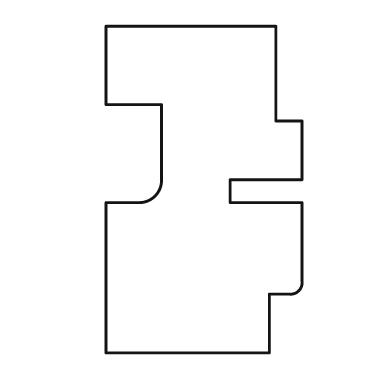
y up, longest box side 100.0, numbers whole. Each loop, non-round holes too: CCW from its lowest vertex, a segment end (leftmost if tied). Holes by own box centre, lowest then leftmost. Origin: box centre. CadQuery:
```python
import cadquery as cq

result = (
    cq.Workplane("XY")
    .moveTo(-30.0, -50.0)
    .lineTo(20.0, -50.0)
    .lineTo(20.0, -32.0)
    .lineTo(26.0, -32.0)
    .threePointArc((29.0, -31.0), (30.0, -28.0))
    .lineTo(30.0, -4.0)
    .lineTo(8.0, -4.0)
    .lineTo(8.0, 3.0)
    .lineTo(30.0, 3.0)
    .lineTo(30.0, 21.0)
    .lineTo(22.0, 21.0)
    .lineTo(22.0, 50.0)
    .lineTo(-30.0, 50.0)
    .lineTo(-30.0, 26.0)
    .lineTo(-13.0, 26.0)
    .lineTo(-13.0, 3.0)
    .threePointArc((-15.0, -2.0), (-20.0, -4.0))
    .lineTo(-30.0, -4.0)
    .close()
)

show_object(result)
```